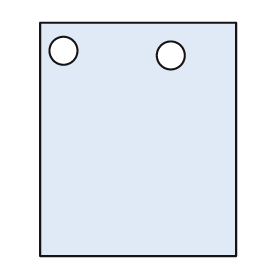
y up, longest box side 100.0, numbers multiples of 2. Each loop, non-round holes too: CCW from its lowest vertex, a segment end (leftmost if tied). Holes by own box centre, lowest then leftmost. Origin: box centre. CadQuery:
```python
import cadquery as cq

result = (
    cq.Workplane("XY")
    .moveTo(-42.0, -50.0)
    .lineTo(42.0, -50.0)
    .lineTo(42.0, 50.0)
    .lineTo(-42.0, 50.0)
    .close()
    .moveTo(14.0, 36.0)
    .circle(6.0)
    .moveTo(-32.0, 38.0)
    .circle(6.0)
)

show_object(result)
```